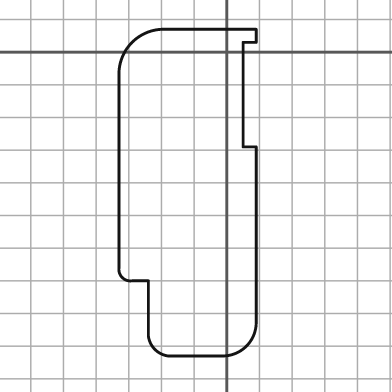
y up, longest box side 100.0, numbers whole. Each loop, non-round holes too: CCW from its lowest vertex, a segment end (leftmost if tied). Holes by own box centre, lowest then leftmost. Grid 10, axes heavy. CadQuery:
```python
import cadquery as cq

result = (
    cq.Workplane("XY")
    .moveTo(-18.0, -93.0)
    .lineTo(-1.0, -93.0)
    .threePointArc((6.0, -90.0), (9.0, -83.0))
    .lineTo(9.0, -29.0)
    .lineTo(5.0, -29.0)
    .lineTo(5.0, 3.0)
    .lineTo(9.0, 3.0)
    .lineTo(9.0, 7.0)
    .lineTo(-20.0, 7.0)
    .threePointArc((-29.0, 3.0), (-33.0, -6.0))
    .lineTo(-33.0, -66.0)
    .threePointArc((-32.0, -69.0), (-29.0, -70.0))
    .lineTo(-24.0, -70.0)
    .lineTo(-24.0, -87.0)
    .threePointArc((-22.0, -91.0), (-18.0, -93.0))
    .close()
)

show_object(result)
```